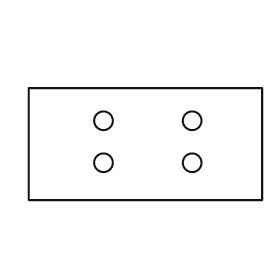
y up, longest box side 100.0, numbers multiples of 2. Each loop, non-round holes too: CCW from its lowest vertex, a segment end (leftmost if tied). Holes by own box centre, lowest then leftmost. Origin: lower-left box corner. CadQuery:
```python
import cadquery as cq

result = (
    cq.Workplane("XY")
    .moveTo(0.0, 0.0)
    .lineTo(100.0, 0.0)
    .lineTo(100.0, 48.0)
    .lineTo(0.0, 48.0)
    .close()
    .moveTo(32.0, 16.0)
    .circle(4.0)
    .moveTo(70.0, 16.0)
    .circle(4.0)
    .moveTo(32.0, 34.0)
    .circle(4.0)
    .moveTo(70.0, 34.0)
    .circle(4.0)
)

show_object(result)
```